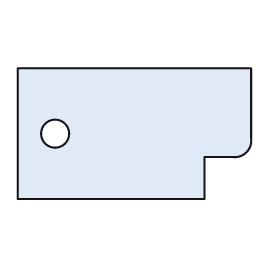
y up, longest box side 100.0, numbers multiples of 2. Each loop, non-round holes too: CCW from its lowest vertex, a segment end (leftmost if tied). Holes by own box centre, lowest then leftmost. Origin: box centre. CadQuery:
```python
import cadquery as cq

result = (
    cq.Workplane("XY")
    .moveTo(-50.0, -28.0)
    .lineTo(30.0, -28.0)
    .lineTo(30.0, -10.0)
    .lineTo(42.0, -10.0)
    .threePointArc((48.0, -8.0), (50.0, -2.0))
    .lineTo(50.0, 28.0)
    .lineTo(-50.0, 28.0)
    .close()
    .moveTo(-34.0, 0.0)
    .circle(6.0)
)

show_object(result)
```